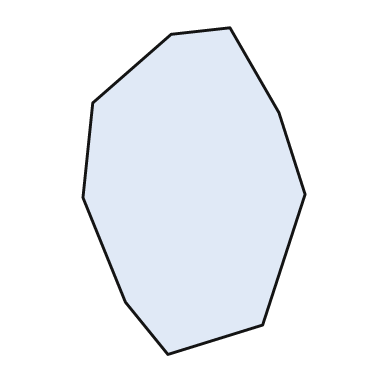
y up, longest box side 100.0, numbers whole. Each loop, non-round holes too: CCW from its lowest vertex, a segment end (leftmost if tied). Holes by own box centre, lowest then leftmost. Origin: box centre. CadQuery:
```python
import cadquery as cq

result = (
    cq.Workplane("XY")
    .moveTo(-8.0, -50.0)
    .lineTo(21.0, -41.0)
    .lineTo(34.0, -1.0)
    .lineTo(26.0, 24.0)
    .lineTo(11.0, 50.0)
    .lineTo(-7.0, 48.0)
    .lineTo(-31.0, 27.0)
    .lineTo(-34.0, -2.0)
    .lineTo(-21.0, -34.0)
    .close()
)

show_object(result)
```